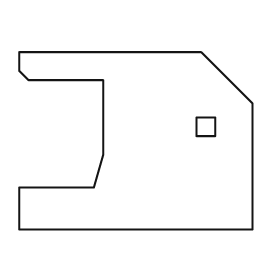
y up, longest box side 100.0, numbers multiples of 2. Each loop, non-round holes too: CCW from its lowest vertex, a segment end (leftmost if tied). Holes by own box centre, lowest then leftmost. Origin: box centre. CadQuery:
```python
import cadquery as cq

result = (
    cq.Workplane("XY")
    .moveTo(-50.0, -38.0)
    .lineTo(50.0, -38.0)
    .lineTo(50.0, 16.0)
    .lineTo(28.0, 38.0)
    .lineTo(-50.0, 38.0)
    .lineTo(-50.0, 30.0)
    .lineTo(-46.0, 26.0)
    .lineTo(-14.0, 26.0)
    .lineTo(-14.0, -6.0)
    .lineTo(-18.0, -20.0)
    .lineTo(-50.0, -20.0)
    .close()
    .moveTo(26.0, 2.0)
    .lineTo(34.0, 2.0)
    .lineTo(34.0, 10.0)
    .lineTo(26.0, 10.0)
    .close()
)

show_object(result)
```